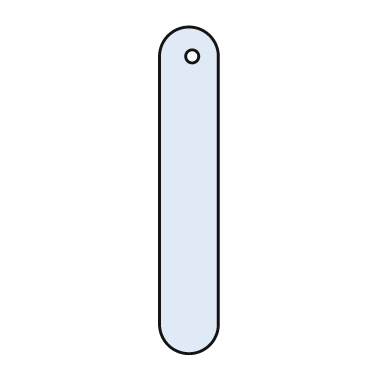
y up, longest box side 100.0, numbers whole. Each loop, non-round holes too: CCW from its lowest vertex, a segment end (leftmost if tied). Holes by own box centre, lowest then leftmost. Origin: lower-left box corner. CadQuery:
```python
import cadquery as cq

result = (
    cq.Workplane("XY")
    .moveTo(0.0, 9.0)
    .threePointArc((9.0, 0.0), (18.0, 9.0))
    .lineTo(18.0, 91.0)
    .threePointArc((9.0, 100.0), (0.0, 91.0))
    .close()
    .moveTo(10.0, 91.0)
    .circle(2.0)
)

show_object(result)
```